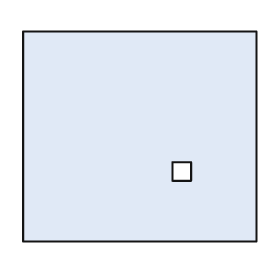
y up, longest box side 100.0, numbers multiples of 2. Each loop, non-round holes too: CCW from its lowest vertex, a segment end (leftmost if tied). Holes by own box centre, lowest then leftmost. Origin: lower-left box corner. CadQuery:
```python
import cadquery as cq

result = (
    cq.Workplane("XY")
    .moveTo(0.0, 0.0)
    .lineTo(100.0, 0.0)
    .lineTo(100.0, 90.0)
    .lineTo(0.0, 90.0)
    .close()
    .moveTo(64.0, 26.0)
    .lineTo(72.0, 26.0)
    .lineTo(72.0, 34.0)
    .lineTo(64.0, 34.0)
    .close()
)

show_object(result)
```